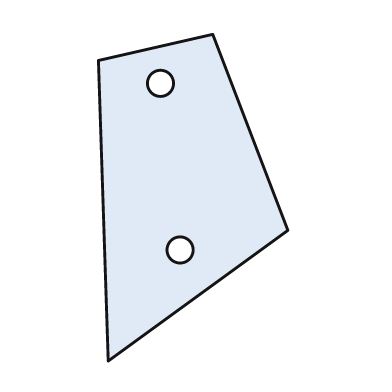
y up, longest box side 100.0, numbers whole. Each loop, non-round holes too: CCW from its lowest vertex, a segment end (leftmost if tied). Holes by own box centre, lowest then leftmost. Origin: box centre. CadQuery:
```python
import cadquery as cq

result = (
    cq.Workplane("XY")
    .moveTo(-26.0, -50.0)
    .lineTo(29.0, -10.0)
    .lineTo(6.0, 50.0)
    .lineTo(-29.0, 42.0)
    .close()
    .moveTo(-4.0, -16.0)
    .circle(4.0)
    .moveTo(-10.0, 35.0)
    .circle(4.0)
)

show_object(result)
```